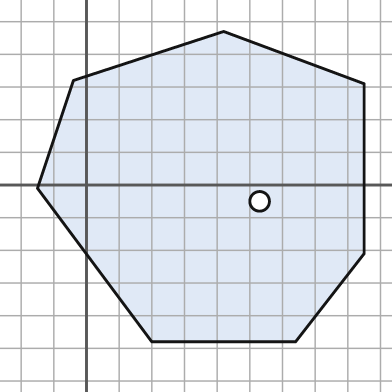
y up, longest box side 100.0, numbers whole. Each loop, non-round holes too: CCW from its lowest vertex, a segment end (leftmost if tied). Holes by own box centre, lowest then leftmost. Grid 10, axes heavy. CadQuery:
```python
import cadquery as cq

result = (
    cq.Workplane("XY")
    .moveTo(20.0, -48.0)
    .lineTo(64.0, -48.0)
    .lineTo(85.0, -21.0)
    .lineTo(85.0, 31.0)
    .lineTo(42.0, 47.0)
    .lineTo(-4.0, 32.0)
    .lineTo(-15.0, -1.0)
    .close()
    .moveTo(53.0, -5.0)
    .circle(3.0)
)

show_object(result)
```